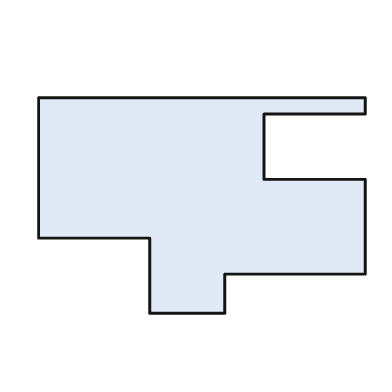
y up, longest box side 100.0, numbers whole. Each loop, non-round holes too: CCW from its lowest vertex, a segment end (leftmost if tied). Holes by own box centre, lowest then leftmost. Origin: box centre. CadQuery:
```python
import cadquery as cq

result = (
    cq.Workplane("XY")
    .moveTo(-16.0, -33.0)
    .lineTo(7.0, -33.0)
    .lineTo(7.0, -21.0)
    .lineTo(50.0, -21.0)
    .lineTo(50.0, 8.0)
    .lineTo(19.0, 8.0)
    .lineTo(19.0, 28.0)
    .lineTo(50.0, 28.0)
    .lineTo(50.0, 33.0)
    .lineTo(-50.0, 33.0)
    .lineTo(-50.0, -10.0)
    .lineTo(-16.0, -10.0)
    .close()
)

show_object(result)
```